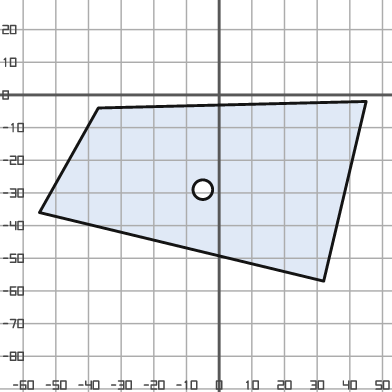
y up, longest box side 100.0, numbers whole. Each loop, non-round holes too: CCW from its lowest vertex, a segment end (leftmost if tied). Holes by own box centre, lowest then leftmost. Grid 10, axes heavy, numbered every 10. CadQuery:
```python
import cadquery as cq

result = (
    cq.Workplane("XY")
    .moveTo(32.0, -57.0)
    .lineTo(45.0, -2.0)
    .lineTo(-37.0, -4.0)
    .lineTo(-55.0, -36.0)
    .close()
    .moveTo(-5.0, -29.0)
    .circle(3.0)
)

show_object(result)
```